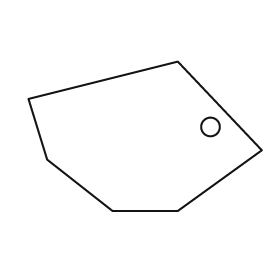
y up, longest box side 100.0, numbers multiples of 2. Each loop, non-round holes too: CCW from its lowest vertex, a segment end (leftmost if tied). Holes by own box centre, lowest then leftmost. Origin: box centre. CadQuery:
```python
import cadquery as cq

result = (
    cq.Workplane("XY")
    .moveTo(-14.0, -32.0)
    .lineTo(14.0, -32.0)
    .lineTo(50.0, -6.0)
    .lineTo(14.0, 32.0)
    .lineTo(-50.0, 16.0)
    .lineTo(-42.0, -10.0)
    .close()
    .moveTo(28.0, 4.0)
    .circle(4.0)
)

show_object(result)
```